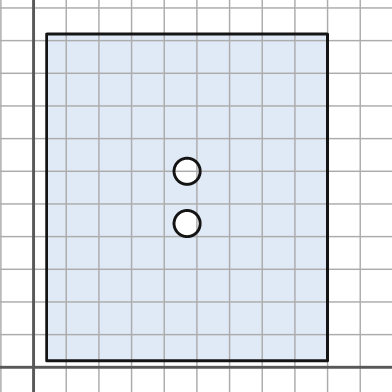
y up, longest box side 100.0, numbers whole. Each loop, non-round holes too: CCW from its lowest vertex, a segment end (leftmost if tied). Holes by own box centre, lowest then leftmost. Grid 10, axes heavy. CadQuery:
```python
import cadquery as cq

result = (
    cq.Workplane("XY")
    .moveTo(4.0, 2.0)
    .lineTo(90.0, 2.0)
    .lineTo(90.0, 102.0)
    .lineTo(4.0, 102.0)
    .close()
    .moveTo(47.0, 44.0)
    .circle(4.0)
    .moveTo(47.0, 60.0)
    .circle(4.0)
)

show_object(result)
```